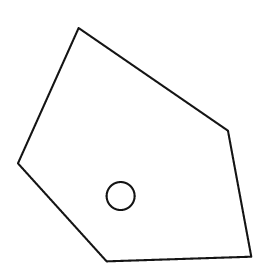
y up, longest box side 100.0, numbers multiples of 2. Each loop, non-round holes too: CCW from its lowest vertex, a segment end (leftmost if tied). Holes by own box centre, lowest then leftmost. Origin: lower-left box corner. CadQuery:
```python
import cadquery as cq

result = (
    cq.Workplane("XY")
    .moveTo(38.0, 0.0)
    .lineTo(100.0, 2.0)
    .lineTo(90.0, 56.0)
    .lineTo(26.0, 100.0)
    .lineTo(0.0, 42.0)
    .close()
    .moveTo(44.0, 28.0)
    .circle(6.0)
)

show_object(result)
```